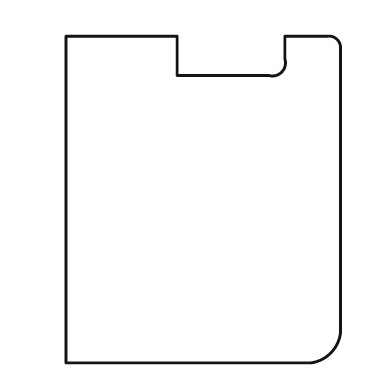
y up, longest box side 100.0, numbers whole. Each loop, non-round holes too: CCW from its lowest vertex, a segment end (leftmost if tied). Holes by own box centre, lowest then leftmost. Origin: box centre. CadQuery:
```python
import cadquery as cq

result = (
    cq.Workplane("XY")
    .moveTo(-42.0, -50.0)
    .lineTo(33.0, -50.0)
    .threePointArc((39.0, -47.0), (42.0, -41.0))
    .lineTo(42.0, 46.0)
    .threePointArc((41.0, 49.0), (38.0, 50.0))
    .lineTo(25.0, 50.0)
    .lineTo(25.0, 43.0)
    .threePointArc((24.0, 39.0), (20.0, 38.0))
    .lineTo(-8.0, 38.0)
    .lineTo(-8.0, 50.0)
    .lineTo(-42.0, 50.0)
    .close()
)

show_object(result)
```